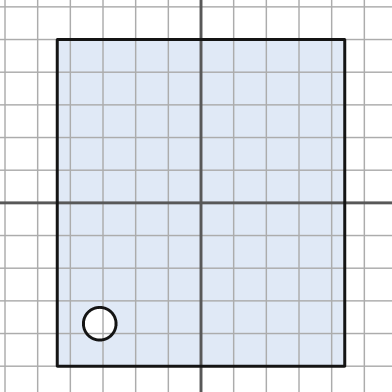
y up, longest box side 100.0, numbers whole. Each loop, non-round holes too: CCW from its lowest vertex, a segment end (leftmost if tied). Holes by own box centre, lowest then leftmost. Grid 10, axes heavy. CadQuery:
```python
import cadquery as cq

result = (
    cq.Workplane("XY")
    .moveTo(-44.0, -50.0)
    .lineTo(44.0, -50.0)
    .lineTo(44.0, 50.0)
    .lineTo(-44.0, 50.0)
    .close()
    .moveTo(-31.0, -37.0)
    .circle(5.0)
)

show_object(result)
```